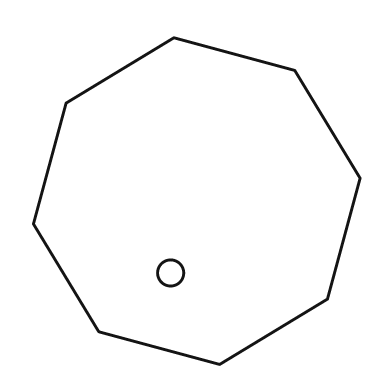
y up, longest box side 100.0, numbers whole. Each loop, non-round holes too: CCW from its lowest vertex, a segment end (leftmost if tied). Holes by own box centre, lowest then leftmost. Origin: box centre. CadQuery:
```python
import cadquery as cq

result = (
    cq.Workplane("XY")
    .moveTo(7.0, -50.0)
    .lineTo(40.0, -30.0)
    .lineTo(50.0, 7.0)
    .lineTo(30.0, 40.0)
    .lineTo(-7.0, 50.0)
    .lineTo(-40.0, 30.0)
    .lineTo(-50.0, -7.0)
    .lineTo(-30.0, -40.0)
    .close()
    .moveTo(-8.0, -22.0)
    .circle(4.0)
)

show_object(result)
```